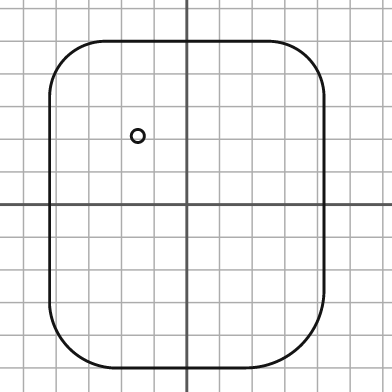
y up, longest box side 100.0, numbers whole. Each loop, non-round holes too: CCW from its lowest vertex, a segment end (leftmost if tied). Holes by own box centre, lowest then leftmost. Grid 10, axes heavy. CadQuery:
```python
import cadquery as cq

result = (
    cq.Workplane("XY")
    .moveTo(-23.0, -50.0)
    .lineTo(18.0, -50.0)
    .threePointArc((35.0, -43.0), (42.0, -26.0))
    .lineTo(42.0, 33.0)
    .threePointArc((37.0, 45.0), (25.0, 50.0))
    .lineTo(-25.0, 50.0)
    .threePointArc((-37.0, 45.0), (-42.0, 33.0))
    .lineTo(-42.0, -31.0)
    .threePointArc((-36.0, -44.0), (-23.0, -50.0))
    .close()
    .moveTo(-15.0, 21.0)
    .circle(2.0)
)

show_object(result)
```